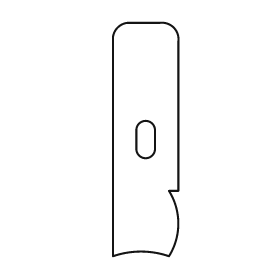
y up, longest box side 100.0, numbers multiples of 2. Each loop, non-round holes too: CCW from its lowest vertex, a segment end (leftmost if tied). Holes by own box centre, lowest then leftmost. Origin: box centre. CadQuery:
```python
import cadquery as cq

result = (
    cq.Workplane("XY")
    .moveTo(-14.0, -50.0)
    .threePointArc((-2.0, -48.0), (10.0, -50.0))
    .threePointArc((14.0, -36.0), (10.0, -22.0))
    .lineTo(14.0, -22.0)
    .lineTo(14.0, 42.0)
    .threePointArc((12.0, 48.0), (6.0, 50.0))
    .lineTo(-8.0, 50.0)
    .threePointArc((-12.0, 48.0), (-14.0, 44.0))
    .close()
    .moveTo(-4.0, -4.0)
    .threePointArc((0.0, -8.0), (4.0, -4.0))
    .lineTo(4.0, 4.0)
    .threePointArc((0.0, 8.0), (-4.0, 4.0))
    .close()
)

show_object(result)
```